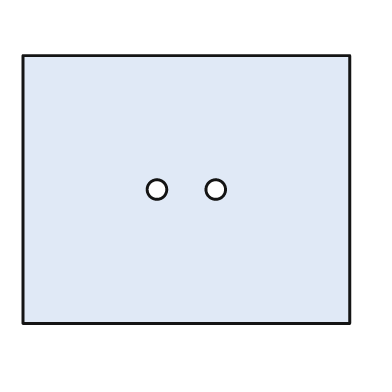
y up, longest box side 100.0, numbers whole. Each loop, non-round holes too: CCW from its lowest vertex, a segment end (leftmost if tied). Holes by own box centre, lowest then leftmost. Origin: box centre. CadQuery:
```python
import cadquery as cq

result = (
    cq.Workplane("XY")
    .moveTo(-50.0, -41.0)
    .lineTo(50.0, -41.0)
    .lineTo(50.0, 41.0)
    .lineTo(-50.0, 41.0)
    .close()
    .moveTo(-9.0, 0.0)
    .circle(3.0)
    .moveTo(9.0, 0.0)
    .circle(3.0)
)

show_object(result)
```